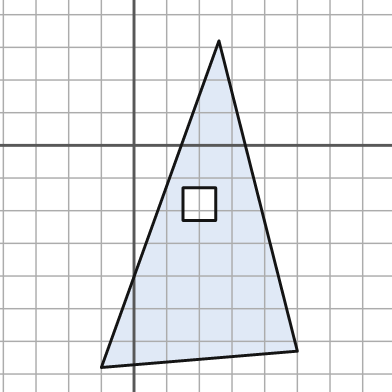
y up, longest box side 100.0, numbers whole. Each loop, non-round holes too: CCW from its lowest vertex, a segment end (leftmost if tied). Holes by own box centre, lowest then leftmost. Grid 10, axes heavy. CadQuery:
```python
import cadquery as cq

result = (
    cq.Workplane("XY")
    .moveTo(-10.0, -68.0)
    .lineTo(50.0, -63.0)
    .lineTo(26.0, 32.0)
    .close()
    .moveTo(15.0, -23.0)
    .lineTo(25.0, -23.0)
    .lineTo(25.0, -13.0)
    .lineTo(15.0, -13.0)
    .close()
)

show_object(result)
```